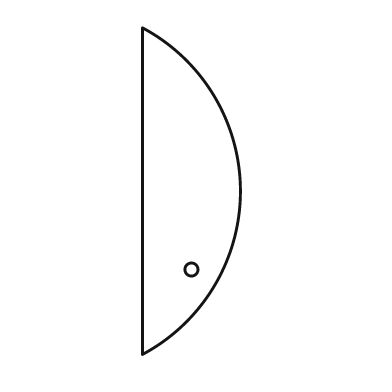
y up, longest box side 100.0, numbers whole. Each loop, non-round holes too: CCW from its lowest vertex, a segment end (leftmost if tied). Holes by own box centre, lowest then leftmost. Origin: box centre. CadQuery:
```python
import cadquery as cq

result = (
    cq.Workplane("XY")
    .moveTo(-15.0, -50.0)
    .threePointArc((15.0, 0.0), (-15.0, 50.0))
    .close()
    .moveTo(0.0, -24.0)
    .circle(2.0)
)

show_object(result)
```